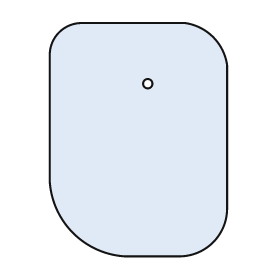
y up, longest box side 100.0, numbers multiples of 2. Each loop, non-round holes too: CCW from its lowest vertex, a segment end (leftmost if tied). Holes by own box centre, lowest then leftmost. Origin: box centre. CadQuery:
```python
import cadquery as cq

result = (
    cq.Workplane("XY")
    .moveTo(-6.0, -50.0)
    .lineTo(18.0, -50.0)
    .threePointArc((32.0, -44.0), (38.0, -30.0))
    .lineTo(38.0, 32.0)
    .threePointArc((32.0, 44.0), (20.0, 50.0))
    .lineTo(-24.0, 50.0)
    .threePointArc((-34.0, 46.0), (-38.0, 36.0))
    .lineTo(-38.0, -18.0)
    .threePointArc((-28.0, -40.0), (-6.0, -50.0))
    .close()
    .moveTo(4.0, 24.0)
    .circle(2.0)
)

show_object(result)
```